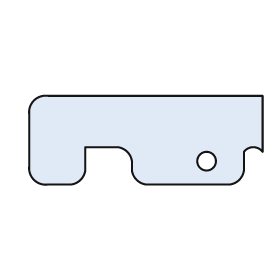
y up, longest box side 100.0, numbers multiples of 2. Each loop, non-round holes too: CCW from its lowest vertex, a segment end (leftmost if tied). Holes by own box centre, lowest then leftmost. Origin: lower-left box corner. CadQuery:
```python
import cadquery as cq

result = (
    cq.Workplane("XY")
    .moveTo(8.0, 0.0)
    .lineTo(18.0, 0.0)
    .threePointArc((22.0, 2.0), (24.0, 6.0))
    .lineTo(24.0, 16.0)
    .lineTo(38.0, 16.0)
    .threePointArc((42.0, 14.0), (44.0, 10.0))
    .lineTo(44.0, 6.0)
    .threePointArc((46.0, 2.0), (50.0, 0.0))
    .lineTo(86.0, 0.0)
    .threePointArc((90.0, 2.0), (92.0, 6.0))
    .lineTo(92.0, 14.0)
    .threePointArc((96.0, 16.0), (100.0, 14.0))
    .lineTo(100.0, 38.0)
    .lineTo(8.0, 38.0)
    .threePointArc((2.0, 36.0), (0.0, 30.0))
    .lineTo(0.0, 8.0)
    .threePointArc((2.0, 2.0), (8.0, 0.0))
    .close()
    .moveTo(76.0, 10.0)
    .circle(4.0)
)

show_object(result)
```